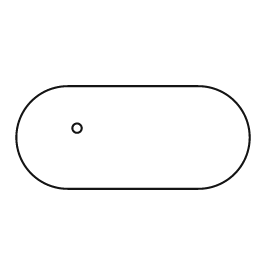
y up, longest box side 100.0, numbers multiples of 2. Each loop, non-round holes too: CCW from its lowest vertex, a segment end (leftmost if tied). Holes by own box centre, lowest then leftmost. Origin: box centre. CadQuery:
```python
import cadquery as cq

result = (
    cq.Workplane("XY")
    .moveTo(-28.0, -22.0)
    .lineTo(28.0, -22.0)
    .threePointArc((50.0, 0.0), (28.0, 22.0))
    .lineTo(-28.0, 22.0)
    .threePointArc((-50.0, 0.0), (-28.0, -22.0))
    .close()
    .moveTo(-24.0, 4.0)
    .circle(2.0)
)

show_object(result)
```